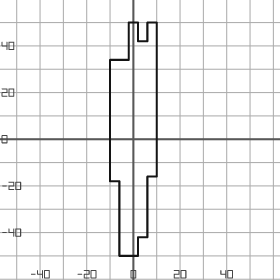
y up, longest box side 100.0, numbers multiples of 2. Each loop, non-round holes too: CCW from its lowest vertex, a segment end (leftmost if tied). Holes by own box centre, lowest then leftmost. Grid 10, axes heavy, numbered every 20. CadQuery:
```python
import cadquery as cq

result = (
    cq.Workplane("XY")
    .moveTo(-6.0, -50.0)
    .lineTo(2.0, -50.0)
    .lineTo(2.0, -42.0)
    .lineTo(6.0, -42.0)
    .lineTo(6.0, -16.0)
    .lineTo(10.0, -16.0)
    .lineTo(10.0, 50.0)
    .lineTo(6.0, 50.0)
    .lineTo(6.0, 42.0)
    .lineTo(2.0, 42.0)
    .lineTo(2.0, 50.0)
    .lineTo(-2.0, 50.0)
    .lineTo(-2.0, 34.0)
    .lineTo(-10.0, 34.0)
    .lineTo(-10.0, -18.0)
    .lineTo(-6.0, -18.0)
    .close()
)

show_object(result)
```